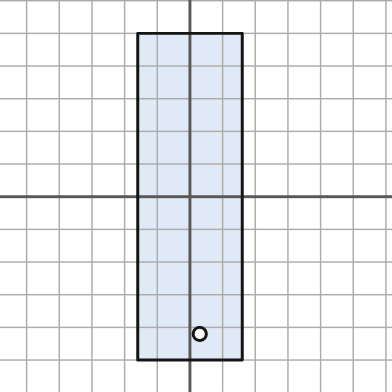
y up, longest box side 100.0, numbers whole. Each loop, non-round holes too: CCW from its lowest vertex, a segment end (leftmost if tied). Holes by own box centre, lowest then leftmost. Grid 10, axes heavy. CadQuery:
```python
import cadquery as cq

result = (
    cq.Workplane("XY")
    .moveTo(-16.0, -50.0)
    .lineTo(16.0, -50.0)
    .lineTo(16.0, 50.0)
    .lineTo(-16.0, 50.0)
    .close()
    .moveTo(3.0, -42.0)
    .circle(2.0)
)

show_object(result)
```